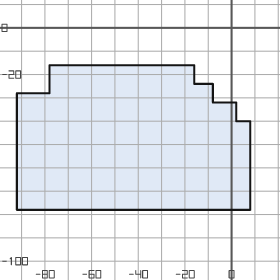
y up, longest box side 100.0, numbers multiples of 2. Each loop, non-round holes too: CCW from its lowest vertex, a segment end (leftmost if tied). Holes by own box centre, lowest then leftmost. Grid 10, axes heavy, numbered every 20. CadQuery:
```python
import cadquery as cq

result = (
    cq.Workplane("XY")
    .moveTo(-92.0, -78.0)
    .lineTo(8.0, -78.0)
    .lineTo(8.0, -40.0)
    .lineTo(2.0, -40.0)
    .lineTo(2.0, -32.0)
    .lineTo(-8.0, -32.0)
    .lineTo(-8.0, -24.0)
    .lineTo(-16.0, -24.0)
    .lineTo(-16.0, -16.0)
    .lineTo(-78.0, -16.0)
    .lineTo(-78.0, -28.0)
    .lineTo(-92.0, -28.0)
    .close()
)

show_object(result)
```